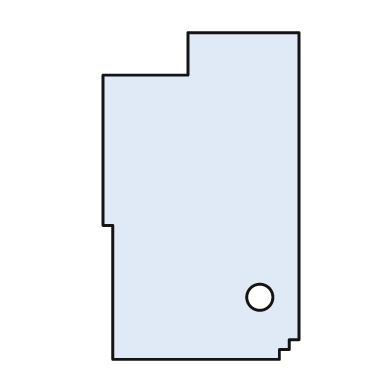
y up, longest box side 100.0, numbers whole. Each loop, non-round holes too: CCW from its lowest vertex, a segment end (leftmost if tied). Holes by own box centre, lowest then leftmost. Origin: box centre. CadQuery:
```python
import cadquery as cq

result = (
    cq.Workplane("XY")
    .moveTo(-27.0, -50.0)
    .lineTo(24.0, -50.0)
    .lineTo(24.0, -47.0)
    .lineTo(27.0, -47.0)
    .lineTo(27.0, -44.0)
    .lineTo(30.0, -44.0)
    .lineTo(30.0, 50.0)
    .lineTo(-4.0, 50.0)
    .lineTo(-4.0, 37.0)
    .lineTo(-30.0, 37.0)
    .lineTo(-30.0, -9.0)
    .lineTo(-27.0, -9.0)
    .close()
    .moveTo(18.0, -31.0)
    .circle(4.0)
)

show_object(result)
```